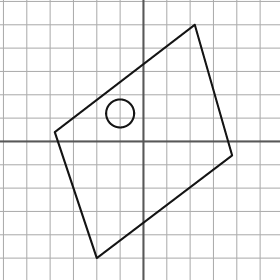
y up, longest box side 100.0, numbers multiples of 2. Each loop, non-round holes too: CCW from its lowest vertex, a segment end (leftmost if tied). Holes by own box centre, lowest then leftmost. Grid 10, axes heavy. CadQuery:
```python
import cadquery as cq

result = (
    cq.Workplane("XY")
    .moveTo(-20.0, -50.0)
    .lineTo(38.0, -6.0)
    .lineTo(22.0, 50.0)
    .lineTo(-38.0, 4.0)
    .close()
    .moveTo(-10.0, 12.0)
    .circle(6.0)
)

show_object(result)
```